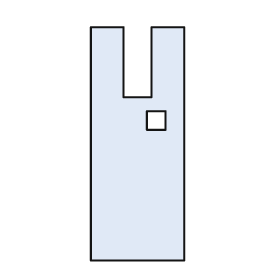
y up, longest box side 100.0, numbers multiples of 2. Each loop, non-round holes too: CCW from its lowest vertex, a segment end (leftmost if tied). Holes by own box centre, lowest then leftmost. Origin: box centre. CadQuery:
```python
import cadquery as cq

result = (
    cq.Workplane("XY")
    .moveTo(-20.0, -50.0)
    .lineTo(20.0, -50.0)
    .lineTo(20.0, 50.0)
    .lineTo(6.0, 50.0)
    .lineTo(6.0, 20.0)
    .lineTo(-6.0, 20.0)
    .lineTo(-6.0, 50.0)
    .lineTo(-20.0, 50.0)
    .close()
    .moveTo(4.0, 6.0)
    .lineTo(12.0, 6.0)
    .lineTo(12.0, 14.0)
    .lineTo(4.0, 14.0)
    .close()
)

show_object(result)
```